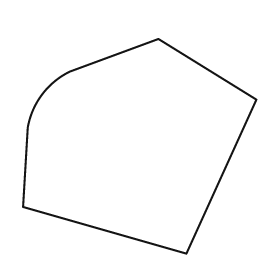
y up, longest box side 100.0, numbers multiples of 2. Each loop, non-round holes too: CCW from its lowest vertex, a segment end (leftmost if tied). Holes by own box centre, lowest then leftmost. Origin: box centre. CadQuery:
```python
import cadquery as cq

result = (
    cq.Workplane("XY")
    .moveTo(20.0, -46.0)
    .lineTo(50.0, 20.0)
    .lineTo(8.0, 46.0)
    .lineTo(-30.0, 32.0)
    .threePointArc((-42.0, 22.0), (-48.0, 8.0))
    .lineTo(-50.0, -26.0)
    .close()
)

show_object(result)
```